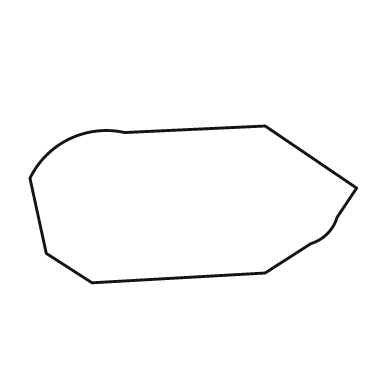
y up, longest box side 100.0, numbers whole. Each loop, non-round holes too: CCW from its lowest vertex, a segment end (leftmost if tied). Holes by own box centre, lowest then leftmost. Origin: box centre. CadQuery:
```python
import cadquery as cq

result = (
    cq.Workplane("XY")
    .moveTo(-31.0, -24.0)
    .lineTo(22.0, -21.0)
    .lineTo(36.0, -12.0)
    .threePointArc((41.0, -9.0), (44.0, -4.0))
    .lineTo(50.0, 5.0)
    .lineTo(22.0, 24.0)
    .lineTo(-21.0, 22.0)
    .threePointArc((-38.0, 20.0), (-50.0, 8.0))
    .lineTo(-45.0, -15.0)
    .close()
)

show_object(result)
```